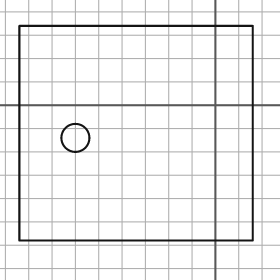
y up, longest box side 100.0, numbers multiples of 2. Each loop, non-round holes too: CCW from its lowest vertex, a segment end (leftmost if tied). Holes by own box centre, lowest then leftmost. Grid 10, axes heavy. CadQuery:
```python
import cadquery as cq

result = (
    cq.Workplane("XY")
    .moveTo(-84.0, -58.0)
    .lineTo(16.0, -58.0)
    .lineTo(16.0, 34.0)
    .lineTo(-84.0, 34.0)
    .close()
    .moveTo(-60.0, -14.0)
    .circle(6.0)
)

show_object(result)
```